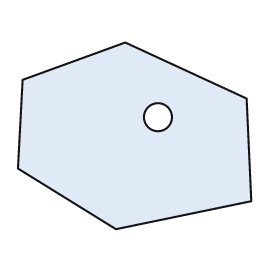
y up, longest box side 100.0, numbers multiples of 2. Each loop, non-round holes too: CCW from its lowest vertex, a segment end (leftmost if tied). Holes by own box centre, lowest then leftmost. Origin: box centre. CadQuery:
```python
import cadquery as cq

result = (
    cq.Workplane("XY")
    .moveTo(-8.0, -40.0)
    .lineTo(50.0, -28.0)
    .lineTo(48.0, 16.0)
    .lineTo(-4.0, 40.0)
    .lineTo(-48.0, 24.0)
    .lineTo(-50.0, -14.0)
    .close()
    .moveTo(10.0, 8.0)
    .circle(6.0)
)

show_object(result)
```